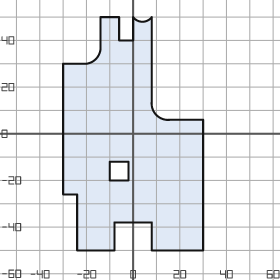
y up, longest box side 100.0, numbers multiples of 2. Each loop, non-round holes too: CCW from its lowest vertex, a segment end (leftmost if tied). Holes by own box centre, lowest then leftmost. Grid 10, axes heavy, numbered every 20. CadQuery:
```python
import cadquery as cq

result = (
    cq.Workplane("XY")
    .moveTo(-24.0, -50.0)
    .lineTo(-8.0, -50.0)
    .lineTo(-8.0, -38.0)
    .lineTo(8.0, -38.0)
    .lineTo(8.0, -50.0)
    .lineTo(30.0, -50.0)
    .lineTo(30.0, 6.0)
    .lineTo(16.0, 6.0)
    .threePointArc((10.0, 8.0), (8.0, 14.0))
    .lineTo(8.0, 50.0)
    .threePointArc((4.0, 48.0), (0.0, 50.0))
    .lineTo(0.0, 40.0)
    .lineTo(-6.0, 40.0)
    .lineTo(-6.0, 50.0)
    .lineTo(-14.0, 50.0)
    .lineTo(-14.0, 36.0)
    .threePointArc((-16.0, 32.0), (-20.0, 30.0))
    .lineTo(-30.0, 30.0)
    .lineTo(-30.0, -26.0)
    .lineTo(-24.0, -26.0)
    .close()
    .moveTo(-10.0, -20.0)
    .lineTo(-2.0, -20.0)
    .lineTo(-2.0, -12.0)
    .lineTo(-10.0, -12.0)
    .close()
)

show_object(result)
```